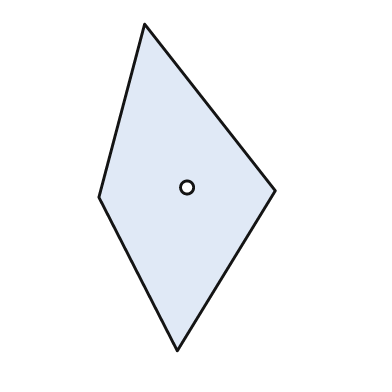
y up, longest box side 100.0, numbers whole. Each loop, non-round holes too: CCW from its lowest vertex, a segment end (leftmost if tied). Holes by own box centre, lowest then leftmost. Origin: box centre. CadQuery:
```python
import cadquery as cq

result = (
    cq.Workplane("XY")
    .moveTo(-3.0, -50.0)
    .lineTo(27.0, -1.0)
    .lineTo(-13.0, 50.0)
    .lineTo(-27.0, -3.0)
    .close()
    .moveTo(0.0, 0.0)
    .circle(2.0)
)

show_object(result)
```